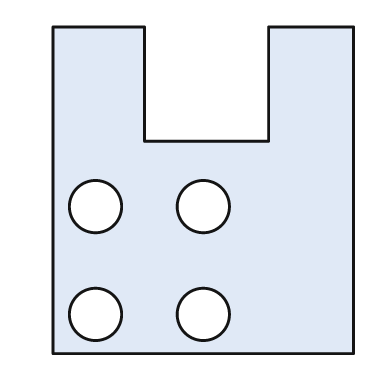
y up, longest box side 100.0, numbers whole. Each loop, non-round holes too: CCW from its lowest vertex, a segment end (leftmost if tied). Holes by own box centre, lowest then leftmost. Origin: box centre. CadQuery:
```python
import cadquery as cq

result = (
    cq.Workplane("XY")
    .moveTo(-46.0, -50.0)
    .lineTo(46.0, -50.0)
    .lineTo(46.0, 50.0)
    .lineTo(20.0, 50.0)
    .lineTo(20.0, 15.0)
    .lineTo(-18.0, 15.0)
    .lineTo(-18.0, 50.0)
    .lineTo(-46.0, 50.0)
    .close()
    .moveTo(-33.0, -38.0)
    .circle(8.0)
    .moveTo(0.0, -38.0)
    .circle(8.0)
    .moveTo(-33.0, -5.0)
    .circle(8.0)
    .moveTo(0.0, -5.0)
    .circle(8.0)
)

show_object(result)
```